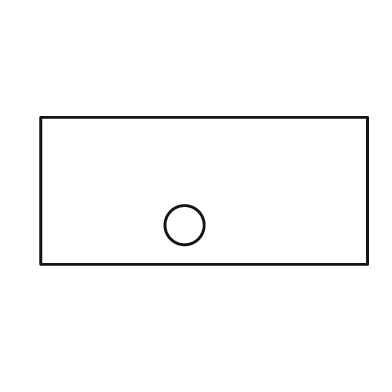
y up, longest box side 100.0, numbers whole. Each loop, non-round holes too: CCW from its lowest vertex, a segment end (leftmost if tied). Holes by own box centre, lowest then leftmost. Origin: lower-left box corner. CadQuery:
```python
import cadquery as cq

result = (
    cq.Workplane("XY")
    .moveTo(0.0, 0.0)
    .lineTo(100.0, 0.0)
    .lineTo(100.0, 45.0)
    .lineTo(0.0, 45.0)
    .close()
    .moveTo(44.0, 12.0)
    .circle(6.0)
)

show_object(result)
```